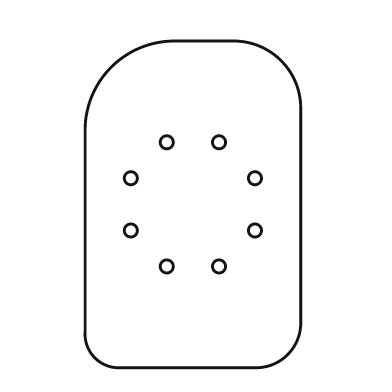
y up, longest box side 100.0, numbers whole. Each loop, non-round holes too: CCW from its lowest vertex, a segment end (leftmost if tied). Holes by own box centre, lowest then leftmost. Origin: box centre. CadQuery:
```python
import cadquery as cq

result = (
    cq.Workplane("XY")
    .moveTo(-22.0, -50.0)
    .lineTo(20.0, -50.0)
    .threePointArc((29.0, -46.0), (33.0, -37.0))
    .lineTo(33.0, 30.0)
    .threePointArc((27.0, 44.0), (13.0, 50.0))
    .lineTo(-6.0, 50.0)
    .threePointArc((-25.0, 42.0), (-33.0, 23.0))
    .lineTo(-33.0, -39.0)
    .threePointArc((-30.0, -47.0), (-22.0, -50.0))
    .close()
    .moveTo(-8.0, -19.0)
    .circle(2.0)
    .moveTo(8.0, -19.0)
    .circle(2.0)
    .moveTo(-19.0, -8.0)
    .circle(2.0)
    .moveTo(19.0, -8.0)
    .circle(2.0)
    .moveTo(-19.0, 8.0)
    .circle(2.0)
    .moveTo(19.0, 8.0)
    .circle(2.0)
    .moveTo(-8.0, 19.0)
    .circle(2.0)
    .moveTo(8.0, 19.0)
    .circle(2.0)
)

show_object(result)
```